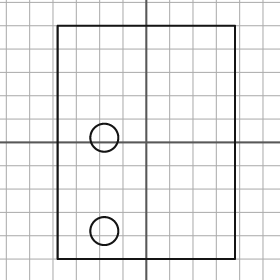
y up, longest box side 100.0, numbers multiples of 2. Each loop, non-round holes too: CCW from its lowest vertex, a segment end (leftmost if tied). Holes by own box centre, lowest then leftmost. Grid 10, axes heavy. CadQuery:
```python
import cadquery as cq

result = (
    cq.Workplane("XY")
    .moveTo(-38.0, -50.0)
    .lineTo(38.0, -50.0)
    .lineTo(38.0, 50.0)
    .lineTo(-38.0, 50.0)
    .close()
    .moveTo(-18.0, -38.0)
    .circle(6.0)
    .moveTo(-18.0, 2.0)
    .circle(6.0)
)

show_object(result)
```